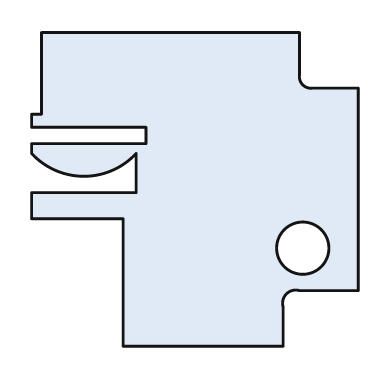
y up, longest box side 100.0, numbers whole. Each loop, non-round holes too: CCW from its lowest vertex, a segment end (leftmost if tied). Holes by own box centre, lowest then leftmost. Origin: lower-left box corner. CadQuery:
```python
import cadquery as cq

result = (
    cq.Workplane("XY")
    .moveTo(28.0, 0.0)
    .lineTo(77.0, 0.0)
    .lineTo(77.0, 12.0)
    .threePointArc((78.0, 16.0), (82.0, 17.0))
    .lineTo(100.0, 17.0)
    .lineTo(100.0, 79.0)
    .lineTo(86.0, 79.0)
    .threePointArc((83.0, 80.0), (82.0, 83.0))
    .lineTo(82.0, 96.0)
    .lineTo(3.0, 96.0)
    .lineTo(3.0, 71.0)
    .lineTo(0.0, 71.0)
    .lineTo(0.0, 67.0)
    .lineTo(35.0, 67.0)
    .lineTo(35.0, 62.0)
    .lineTo(0.0, 62.0)
    .lineTo(0.0, 59.0)
    .threePointArc((16.0, 52.0), (32.0, 59.0))
    .lineTo(32.0, 47.0)
    .lineTo(0.0, 47.0)
    .lineTo(0.0, 39.0)
    .lineTo(28.0, 39.0)
    .close()
    .moveTo(83.0, 30.0)
    .circle(8.0)
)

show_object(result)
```